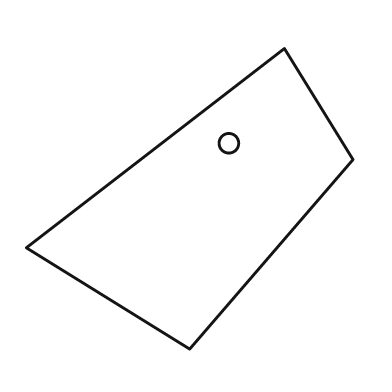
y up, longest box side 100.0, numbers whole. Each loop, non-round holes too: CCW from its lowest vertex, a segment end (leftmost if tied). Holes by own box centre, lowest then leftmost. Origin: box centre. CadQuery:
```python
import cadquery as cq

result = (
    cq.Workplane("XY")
    .moveTo(0.0, -46.0)
    .lineTo(50.0, 12.0)
    .lineTo(29.0, 46.0)
    .lineTo(-50.0, -15.0)
    .close()
    .moveTo(12.0, 17.0)
    .circle(3.0)
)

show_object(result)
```